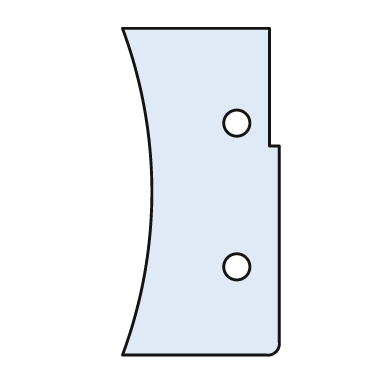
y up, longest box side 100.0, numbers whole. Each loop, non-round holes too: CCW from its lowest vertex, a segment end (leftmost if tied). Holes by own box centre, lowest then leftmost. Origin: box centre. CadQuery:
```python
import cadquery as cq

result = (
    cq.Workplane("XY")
    .moveTo(-24.0, -50.0)
    .lineTo(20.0, -50.0)
    .threePointArc((23.0, -49.0), (24.0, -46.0))
    .lineTo(24.0, 14.0)
    .lineTo(21.0, 14.0)
    .lineTo(21.0, 50.0)
    .lineTo(-24.0, 50.0)
    .threePointArc((-15.0, 0.0), (-24.0, -50.0))
    .close()
    .moveTo(11.0, -23.0)
    .circle(4.0)
    .moveTo(11.0, 21.0)
    .circle(4.0)
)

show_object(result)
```